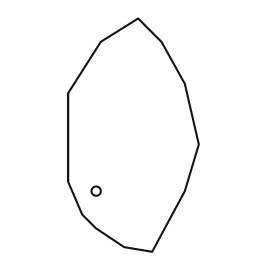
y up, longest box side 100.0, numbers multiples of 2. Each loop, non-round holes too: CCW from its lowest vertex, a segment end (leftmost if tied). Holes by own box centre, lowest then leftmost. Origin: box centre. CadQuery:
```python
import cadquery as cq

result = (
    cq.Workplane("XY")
    .moveTo(8.0, -50.0)
    .lineTo(22.0, -24.0)
    .lineTo(28.0, -4.0)
    .lineTo(22.0, 22.0)
    .lineTo(12.0, 40.0)
    .lineTo(2.0, 50.0)
    .lineTo(-14.0, 40.0)
    .lineTo(-28.0, 18.0)
    .lineTo(-28.0, -20.0)
    .lineTo(-22.0, -34.0)
    .lineTo(-16.0, -40.0)
    .lineTo(-4.0, -48.0)
    .close()
    .moveTo(-16.0, -24.0)
    .circle(2.0)
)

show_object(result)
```